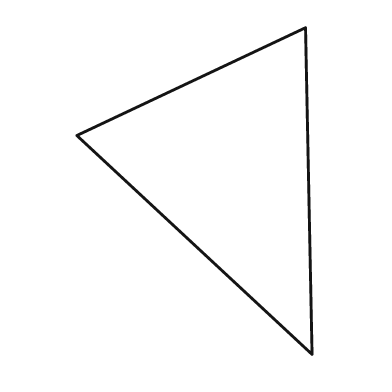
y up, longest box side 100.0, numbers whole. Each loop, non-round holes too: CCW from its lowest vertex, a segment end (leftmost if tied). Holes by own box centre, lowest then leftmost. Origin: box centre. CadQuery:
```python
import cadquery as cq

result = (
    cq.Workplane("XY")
    .moveTo(36.0, -50.0)
    .lineTo(34.0, 50.0)
    .lineTo(-36.0, 17.0)
    .close()
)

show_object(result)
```